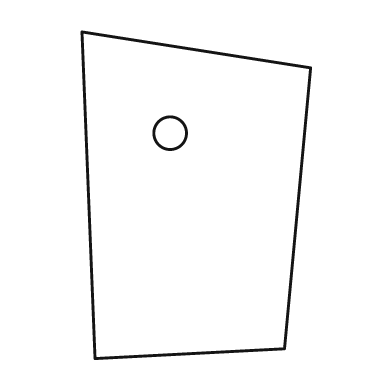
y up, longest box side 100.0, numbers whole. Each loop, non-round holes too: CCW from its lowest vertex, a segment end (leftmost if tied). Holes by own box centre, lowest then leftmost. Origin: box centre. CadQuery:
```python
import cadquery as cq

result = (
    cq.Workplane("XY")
    .moveTo(-31.0, -50.0)
    .lineTo(27.0, -47.0)
    .lineTo(35.0, 39.0)
    .lineTo(-35.0, 50.0)
    .close()
    .moveTo(-8.0, 19.0)
    .circle(5.0)
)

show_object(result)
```